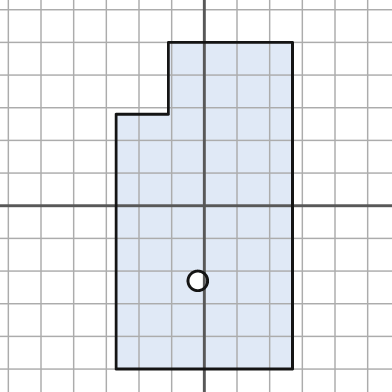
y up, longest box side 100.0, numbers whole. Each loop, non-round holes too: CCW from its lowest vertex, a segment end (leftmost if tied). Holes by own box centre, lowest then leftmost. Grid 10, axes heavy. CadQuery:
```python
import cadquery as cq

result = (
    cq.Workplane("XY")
    .moveTo(-27.0, -50.0)
    .lineTo(27.0, -50.0)
    .lineTo(27.0, 50.0)
    .lineTo(-11.0, 50.0)
    .lineTo(-11.0, 28.0)
    .lineTo(-27.0, 28.0)
    .close()
    .moveTo(-2.0, -23.0)
    .circle(3.0)
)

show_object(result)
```